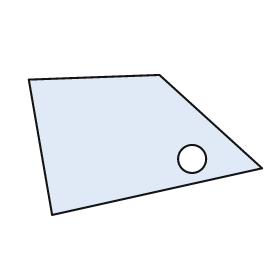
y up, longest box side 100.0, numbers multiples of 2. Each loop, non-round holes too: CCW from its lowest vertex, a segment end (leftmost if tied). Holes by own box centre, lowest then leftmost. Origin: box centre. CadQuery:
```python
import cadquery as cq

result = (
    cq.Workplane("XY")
    .moveTo(-40.0, -30.0)
    .lineTo(50.0, -10.0)
    .lineTo(6.0, 30.0)
    .lineTo(-50.0, 28.0)
    .close()
    .moveTo(20.0, -6.0)
    .circle(6.0)
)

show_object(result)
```